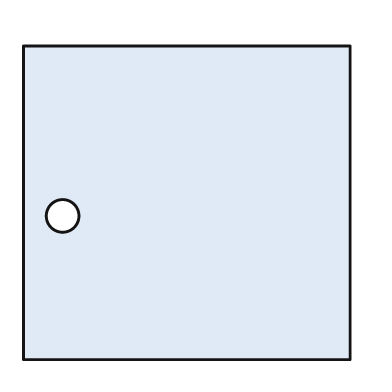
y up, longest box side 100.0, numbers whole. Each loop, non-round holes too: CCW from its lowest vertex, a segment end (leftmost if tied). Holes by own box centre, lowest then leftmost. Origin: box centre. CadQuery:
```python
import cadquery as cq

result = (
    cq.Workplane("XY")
    .moveTo(-50.0, -48.0)
    .lineTo(50.0, -48.0)
    .lineTo(50.0, 48.0)
    .lineTo(-50.0, 48.0)
    .close()
    .moveTo(-38.0, -4.0)
    .circle(5.0)
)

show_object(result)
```